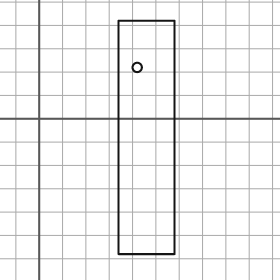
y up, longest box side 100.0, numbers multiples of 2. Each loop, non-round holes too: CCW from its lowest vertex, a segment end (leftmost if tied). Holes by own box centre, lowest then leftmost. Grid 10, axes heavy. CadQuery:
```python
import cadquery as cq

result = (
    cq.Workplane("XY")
    .moveTo(34.0, -58.0)
    .lineTo(58.0, -58.0)
    .lineTo(58.0, 42.0)
    .lineTo(34.0, 42.0)
    .close()
    .moveTo(42.0, 22.0)
    .circle(2.0)
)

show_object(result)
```